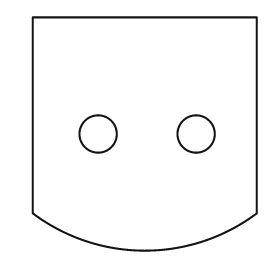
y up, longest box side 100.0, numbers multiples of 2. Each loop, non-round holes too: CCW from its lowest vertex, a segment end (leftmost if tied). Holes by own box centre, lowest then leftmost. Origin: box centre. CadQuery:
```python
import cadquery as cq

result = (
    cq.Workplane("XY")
    .moveTo(-48.0, -34.0)
    .threePointArc((0.0, -50.0), (48.0, -34.0))
    .lineTo(48.0, 50.0)
    .lineTo(-48.0, 50.0)
    .close()
    .moveTo(-20.0, 0.0)
    .circle(8.0)
    .moveTo(22.0, 0.0)
    .circle(8.0)
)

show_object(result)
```